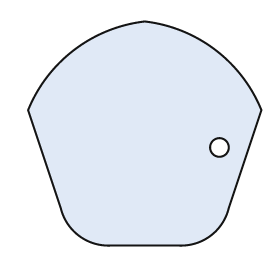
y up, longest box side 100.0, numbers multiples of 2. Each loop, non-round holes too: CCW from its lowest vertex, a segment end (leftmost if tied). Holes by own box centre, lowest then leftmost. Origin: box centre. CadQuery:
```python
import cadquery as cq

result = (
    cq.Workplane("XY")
    .moveTo(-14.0, -48.0)
    .lineTo(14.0, -48.0)
    .threePointArc((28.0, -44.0), (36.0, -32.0))
    .lineTo(50.0, 10.0)
    .threePointArc((30.0, 36.0), (0.0, 48.0))
    .threePointArc((-30.0, 36.0), (-50.0, 10.0))
    .lineTo(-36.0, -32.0)
    .threePointArc((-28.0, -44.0), (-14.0, -48.0))
    .close()
    .moveTo(32.0, -6.0)
    .circle(4.0)
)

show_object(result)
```